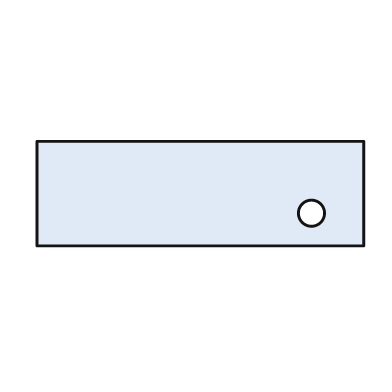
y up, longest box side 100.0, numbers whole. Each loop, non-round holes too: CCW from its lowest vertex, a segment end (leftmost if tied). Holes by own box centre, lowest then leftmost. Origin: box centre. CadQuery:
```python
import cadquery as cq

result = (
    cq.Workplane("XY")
    .moveTo(-50.0, -16.0)
    .lineTo(50.0, -16.0)
    .lineTo(50.0, 16.0)
    .lineTo(-50.0, 16.0)
    .close()
    .moveTo(34.0, -6.0)
    .circle(4.0)
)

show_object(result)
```